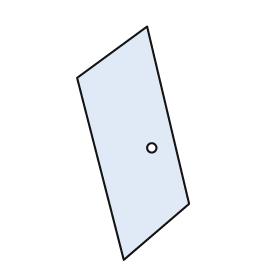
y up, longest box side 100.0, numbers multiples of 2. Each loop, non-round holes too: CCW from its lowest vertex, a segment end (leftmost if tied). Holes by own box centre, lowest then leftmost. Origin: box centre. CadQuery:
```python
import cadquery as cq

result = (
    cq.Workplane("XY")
    .moveTo(-4.0, -50.0)
    .lineTo(24.0, -26.0)
    .lineTo(6.0, 50.0)
    .lineTo(-24.0, 28.0)
    .close()
    .moveTo(8.0, -2.0)
    .circle(2.0)
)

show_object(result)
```